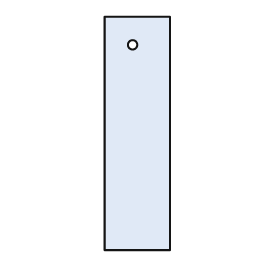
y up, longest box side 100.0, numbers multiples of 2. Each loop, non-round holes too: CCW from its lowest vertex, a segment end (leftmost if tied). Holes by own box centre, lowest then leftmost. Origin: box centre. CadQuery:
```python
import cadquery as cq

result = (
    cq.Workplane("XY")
    .moveTo(-14.0, -50.0)
    .lineTo(14.0, -50.0)
    .lineTo(14.0, 50.0)
    .lineTo(-14.0, 50.0)
    .close()
    .moveTo(-2.0, 38.0)
    .circle(2.0)
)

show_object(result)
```